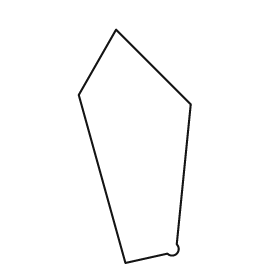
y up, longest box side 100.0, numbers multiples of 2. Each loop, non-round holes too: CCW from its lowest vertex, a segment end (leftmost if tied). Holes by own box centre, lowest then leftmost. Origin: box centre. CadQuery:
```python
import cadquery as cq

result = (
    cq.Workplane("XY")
    .moveTo(-4.0, -50.0)
    .lineTo(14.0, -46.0)
    .threePointArc((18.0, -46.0), (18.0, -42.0))
    .lineTo(24.0, 18.0)
    .lineTo(-8.0, 50.0)
    .lineTo(-24.0, 22.0)
    .close()
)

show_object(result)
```